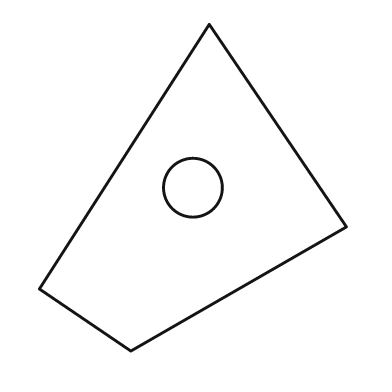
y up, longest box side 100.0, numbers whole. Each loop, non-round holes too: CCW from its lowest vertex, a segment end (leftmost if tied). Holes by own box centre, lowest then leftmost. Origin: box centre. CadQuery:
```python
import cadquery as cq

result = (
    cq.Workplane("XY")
    .moveTo(-19.0, -50.0)
    .lineTo(47.0, -12.0)
    .lineTo(5.0, 50.0)
    .lineTo(-47.0, -31.0)
    .close()
    .moveTo(0.0, 0.0)
    .circle(9.0)
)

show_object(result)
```